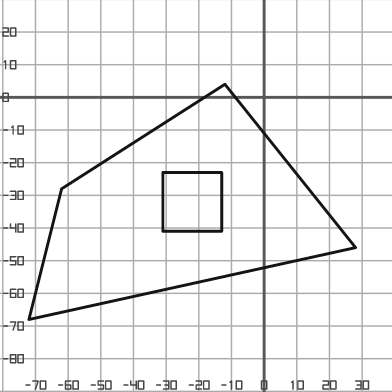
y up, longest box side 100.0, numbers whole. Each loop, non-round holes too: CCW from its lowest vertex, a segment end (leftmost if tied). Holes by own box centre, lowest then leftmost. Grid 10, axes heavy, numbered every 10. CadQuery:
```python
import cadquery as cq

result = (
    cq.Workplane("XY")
    .moveTo(-72.0, -68.0)
    .lineTo(28.0, -46.0)
    .lineTo(-12.0, 4.0)
    .lineTo(-62.0, -28.0)
    .close()
    .moveTo(-31.0, -41.0)
    .lineTo(-13.0, -41.0)
    .lineTo(-13.0, -23.0)
    .lineTo(-31.0, -23.0)
    .close()
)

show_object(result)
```